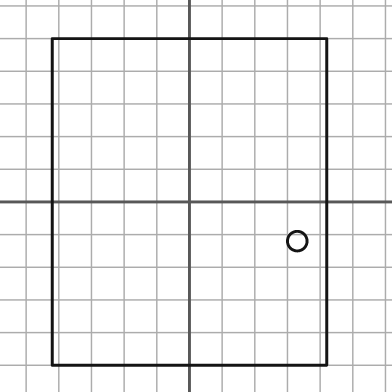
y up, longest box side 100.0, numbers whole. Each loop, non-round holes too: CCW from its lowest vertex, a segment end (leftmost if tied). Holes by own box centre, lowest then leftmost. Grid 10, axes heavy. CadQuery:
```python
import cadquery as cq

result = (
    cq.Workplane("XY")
    .moveTo(-42.0, -50.0)
    .lineTo(42.0, -50.0)
    .lineTo(42.0, 50.0)
    .lineTo(-42.0, 50.0)
    .close()
    .moveTo(33.0, -12.0)
    .circle(3.0)
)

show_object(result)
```